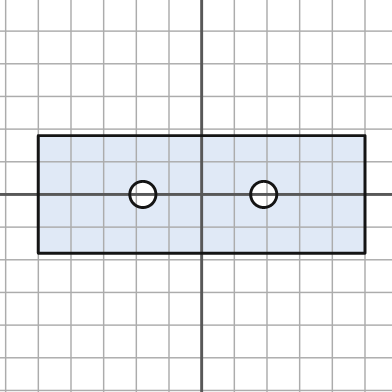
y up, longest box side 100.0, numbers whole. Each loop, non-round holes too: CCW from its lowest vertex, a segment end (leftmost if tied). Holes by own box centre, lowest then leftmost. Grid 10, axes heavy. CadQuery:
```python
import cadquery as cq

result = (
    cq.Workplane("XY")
    .moveTo(-50.0, -18.0)
    .lineTo(50.0, -18.0)
    .lineTo(50.0, 18.0)
    .lineTo(-50.0, 18.0)
    .close()
    .moveTo(-18.0, 0.0)
    .circle(4.0)
    .moveTo(19.0, 0.0)
    .circle(4.0)
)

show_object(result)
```